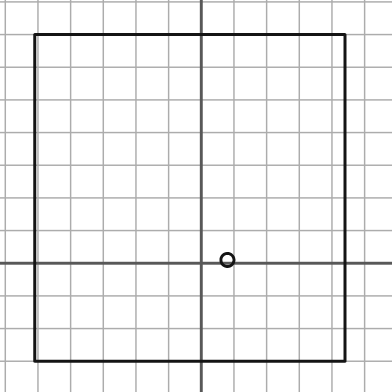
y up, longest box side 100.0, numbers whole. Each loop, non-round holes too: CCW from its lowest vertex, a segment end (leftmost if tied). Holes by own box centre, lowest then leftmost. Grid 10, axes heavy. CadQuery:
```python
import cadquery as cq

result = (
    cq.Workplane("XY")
    .moveTo(-51.0, -30.0)
    .lineTo(44.0, -30.0)
    .lineTo(44.0, 70.0)
    .lineTo(-51.0, 70.0)
    .close()
    .moveTo(8.0, 1.0)
    .circle(2.0)
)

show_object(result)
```